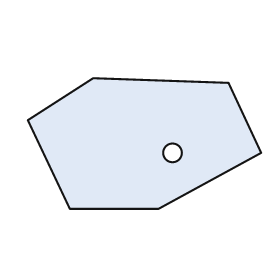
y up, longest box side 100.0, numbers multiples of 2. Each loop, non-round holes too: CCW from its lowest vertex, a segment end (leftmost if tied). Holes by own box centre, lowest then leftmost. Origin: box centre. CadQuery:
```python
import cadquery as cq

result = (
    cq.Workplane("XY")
    .moveTo(-32.0, -28.0)
    .lineTo(6.0, -28.0)
    .lineTo(50.0, -4.0)
    .lineTo(36.0, 26.0)
    .lineTo(-22.0, 28.0)
    .lineTo(-50.0, 10.0)
    .close()
    .moveTo(12.0, -4.0)
    .circle(4.0)
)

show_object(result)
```